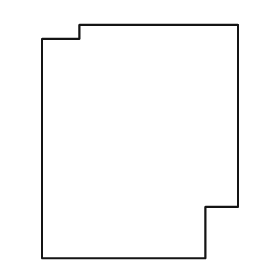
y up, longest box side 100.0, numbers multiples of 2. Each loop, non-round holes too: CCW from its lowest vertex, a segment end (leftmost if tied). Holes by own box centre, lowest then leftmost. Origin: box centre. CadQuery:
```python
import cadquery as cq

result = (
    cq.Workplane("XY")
    .moveTo(-42.0, -50.0)
    .lineTo(28.0, -50.0)
    .lineTo(28.0, -28.0)
    .lineTo(42.0, -28.0)
    .lineTo(42.0, 50.0)
    .lineTo(-26.0, 50.0)
    .lineTo(-26.0, 44.0)
    .lineTo(-42.0, 44.0)
    .close()
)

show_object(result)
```